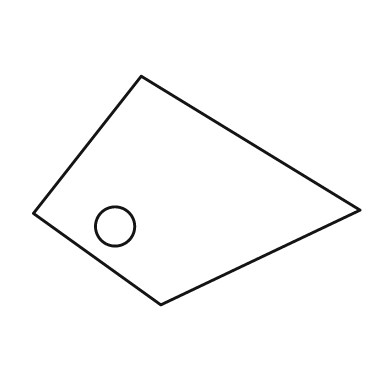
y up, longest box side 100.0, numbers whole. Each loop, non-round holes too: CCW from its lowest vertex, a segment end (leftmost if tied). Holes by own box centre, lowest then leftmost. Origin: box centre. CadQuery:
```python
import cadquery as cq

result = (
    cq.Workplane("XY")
    .moveTo(-11.0, -35.0)
    .lineTo(50.0, -6.0)
    .lineTo(-17.0, 35.0)
    .lineTo(-50.0, -7.0)
    .close()
    .moveTo(-25.0, -11.0)
    .circle(6.0)
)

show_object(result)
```